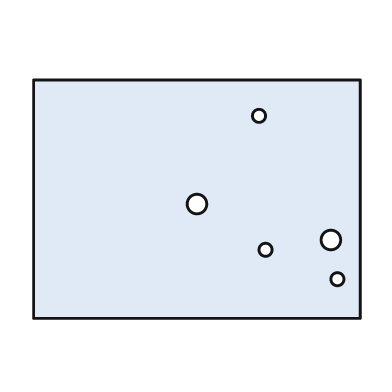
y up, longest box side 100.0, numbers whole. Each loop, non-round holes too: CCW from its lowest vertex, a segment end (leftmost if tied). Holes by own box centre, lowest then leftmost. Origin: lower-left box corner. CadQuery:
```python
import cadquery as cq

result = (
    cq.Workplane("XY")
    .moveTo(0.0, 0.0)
    .lineTo(100.0, 0.0)
    .lineTo(100.0, 73.0)
    .lineTo(0.0, 73.0)
    .close()
    .moveTo(93.0, 12.0)
    .circle(2.0)
    .moveTo(71.0, 21.0)
    .circle(2.0)
    .moveTo(91.0, 24.0)
    .circle(3.0)
    .moveTo(50.0, 35.0)
    .circle(3.0)
    .moveTo(69.0, 62.0)
    .circle(2.0)
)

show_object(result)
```